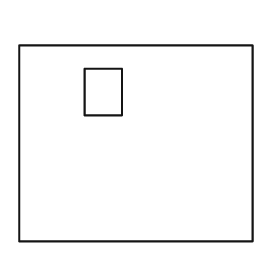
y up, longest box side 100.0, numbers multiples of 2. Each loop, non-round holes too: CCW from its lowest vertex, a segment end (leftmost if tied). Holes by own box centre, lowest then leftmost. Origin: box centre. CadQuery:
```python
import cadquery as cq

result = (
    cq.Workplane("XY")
    .moveTo(-50.0, -42.0)
    .lineTo(50.0, -42.0)
    .lineTo(50.0, 42.0)
    .lineTo(-50.0, 42.0)
    .close()
    .moveTo(-22.0, 12.0)
    .lineTo(-6.0, 12.0)
    .lineTo(-6.0, 32.0)
    .lineTo(-22.0, 32.0)
    .close()
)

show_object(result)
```